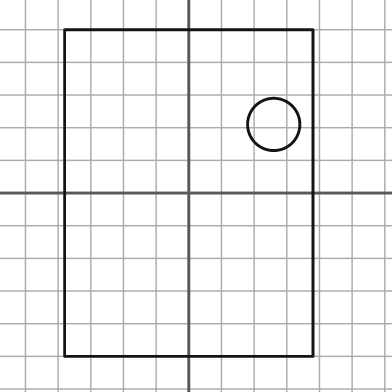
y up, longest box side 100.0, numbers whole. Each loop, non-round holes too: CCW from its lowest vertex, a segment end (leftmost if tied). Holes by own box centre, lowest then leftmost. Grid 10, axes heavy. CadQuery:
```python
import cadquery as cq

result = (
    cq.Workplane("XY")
    .moveTo(-38.0, -50.0)
    .lineTo(38.0, -50.0)
    .lineTo(38.0, 50.0)
    .lineTo(-38.0, 50.0)
    .close()
    .moveTo(26.0, 21.0)
    .circle(8.0)
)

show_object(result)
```